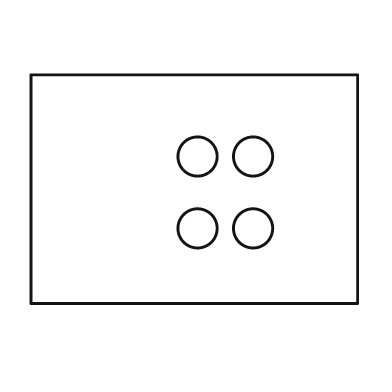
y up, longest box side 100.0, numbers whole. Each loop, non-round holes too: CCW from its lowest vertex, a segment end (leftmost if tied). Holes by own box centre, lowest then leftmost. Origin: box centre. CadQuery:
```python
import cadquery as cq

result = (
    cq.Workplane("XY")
    .moveTo(-50.0, -35.0)
    .lineTo(50.0, -35.0)
    .lineTo(50.0, 35.0)
    .lineTo(-50.0, 35.0)
    .close()
    .moveTo(1.0, -12.0)
    .circle(6.0)
    .moveTo(18.0, -12.0)
    .circle(6.0)
    .moveTo(1.0, 10.0)
    .circle(6.0)
    .moveTo(18.0, 10.0)
    .circle(6.0)
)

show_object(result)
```